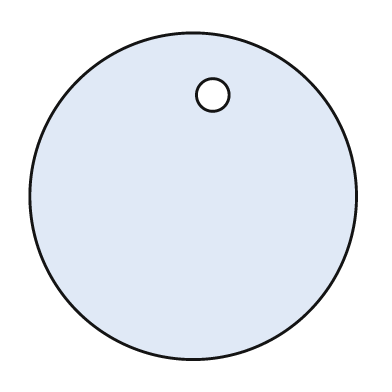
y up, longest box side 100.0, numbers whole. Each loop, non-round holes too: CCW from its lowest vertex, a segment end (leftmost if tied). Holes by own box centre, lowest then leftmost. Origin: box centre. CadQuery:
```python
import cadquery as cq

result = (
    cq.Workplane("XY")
    .moveTo(0.0, 0.0)
    .circle(50.0)
    .moveTo(6.0, 31.0)
    .circle(5.0)
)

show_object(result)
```